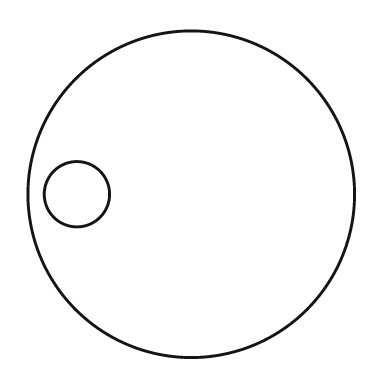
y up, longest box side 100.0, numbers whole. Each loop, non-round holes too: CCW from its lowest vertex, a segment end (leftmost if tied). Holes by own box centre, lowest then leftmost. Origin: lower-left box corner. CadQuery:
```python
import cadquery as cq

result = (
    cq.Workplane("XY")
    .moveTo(50.0, 50.0)
    .circle(50.0)
    .moveTo(15.0, 50.0)
    .circle(10.0)
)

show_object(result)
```